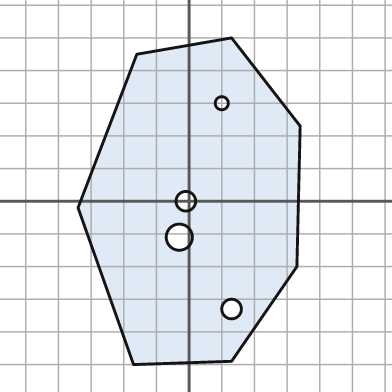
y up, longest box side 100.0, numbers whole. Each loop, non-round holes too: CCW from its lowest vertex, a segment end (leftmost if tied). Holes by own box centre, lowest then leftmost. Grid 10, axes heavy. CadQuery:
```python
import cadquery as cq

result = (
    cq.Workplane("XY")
    .moveTo(-17.0, -50.0)
    .lineTo(13.0, -49.0)
    .lineTo(33.0, -20.0)
    .lineTo(34.0, 23.0)
    .lineTo(13.0, 50.0)
    .lineTo(-16.0, 45.0)
    .lineTo(-34.0, -2.0)
    .close()
    .moveTo(13.0, -33.0)
    .circle(3.0)
    .moveTo(-3.0, -11.0)
    .circle(4.0)
    .moveTo(-1.0, 0.0)
    .circle(3.0)
    .moveTo(10.0, 30.0)
    .circle(2.0)
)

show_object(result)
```